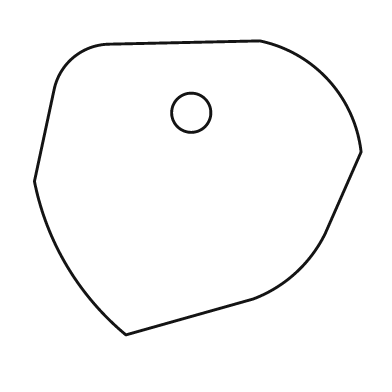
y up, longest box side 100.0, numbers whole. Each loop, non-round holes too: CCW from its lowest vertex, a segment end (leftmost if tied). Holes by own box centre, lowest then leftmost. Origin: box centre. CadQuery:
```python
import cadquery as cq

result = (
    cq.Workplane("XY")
    .moveTo(-22.0, -45.0)
    .lineTo(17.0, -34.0)
    .threePointArc((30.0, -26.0), (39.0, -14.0))
    .lineTo(50.0, 11.0)
    .threePointArc((40.0, 33.0), (19.0, 45.0))
    .lineTo(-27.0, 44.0)
    .threePointArc((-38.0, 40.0), (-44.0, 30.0))
    .lineTo(-50.0, 2.0)
    .threePointArc((-40.0, -24.0), (-22.0, -45.0))
    .close()
    .moveTo(-2.0, 23.0)
    .circle(6.0)
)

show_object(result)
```